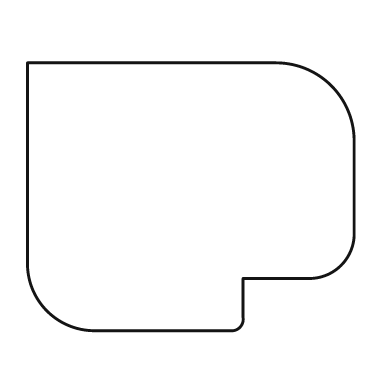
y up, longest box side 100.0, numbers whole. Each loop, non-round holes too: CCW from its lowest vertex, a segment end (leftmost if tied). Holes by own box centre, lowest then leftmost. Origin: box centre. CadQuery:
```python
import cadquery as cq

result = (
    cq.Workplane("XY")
    .moveTo(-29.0, -41.0)
    .lineTo(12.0, -41.0)
    .threePointArc((15.0, -40.0), (16.0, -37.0))
    .lineTo(16.0, -25.0)
    .lineTo(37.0, -25.0)
    .threePointArc((46.0, -21.0), (50.0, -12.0))
    .lineTo(50.0, 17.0)
    .threePointArc((43.0, 34.0), (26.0, 41.0))
    .lineTo(-50.0, 41.0)
    .lineTo(-50.0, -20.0)
    .threePointArc((-44.0, -35.0), (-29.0, -41.0))
    .close()
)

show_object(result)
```